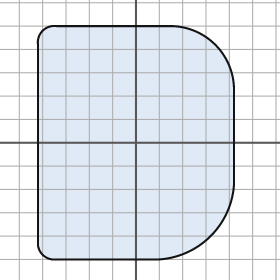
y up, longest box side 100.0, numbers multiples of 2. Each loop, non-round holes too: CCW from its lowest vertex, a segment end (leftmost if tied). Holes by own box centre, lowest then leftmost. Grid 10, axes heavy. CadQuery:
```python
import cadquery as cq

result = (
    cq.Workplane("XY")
    .moveTo(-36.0, -50.0)
    .lineTo(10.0, -50.0)
    .threePointArc((32.0, -40.0), (42.0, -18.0))
    .lineTo(42.0, 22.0)
    .threePointArc((34.0, 42.0), (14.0, 50.0))
    .lineTo(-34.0, 50.0)
    .threePointArc((-40.0, 48.0), (-42.0, 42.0))
    .lineTo(-42.0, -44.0)
    .threePointArc((-40.0, -48.0), (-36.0, -50.0))
    .close()
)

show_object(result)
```